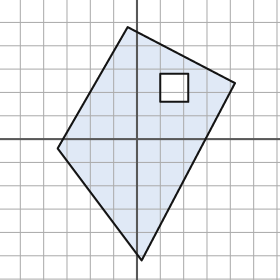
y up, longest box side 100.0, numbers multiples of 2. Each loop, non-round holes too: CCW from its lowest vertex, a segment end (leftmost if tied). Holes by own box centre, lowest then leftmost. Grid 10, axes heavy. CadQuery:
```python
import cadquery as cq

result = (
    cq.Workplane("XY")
    .moveTo(2.0, -52.0)
    .lineTo(42.0, 24.0)
    .lineTo(-4.0, 48.0)
    .lineTo(-34.0, -4.0)
    .close()
    .moveTo(10.0, 16.0)
    .lineTo(22.0, 16.0)
    .lineTo(22.0, 28.0)
    .lineTo(10.0, 28.0)
    .close()
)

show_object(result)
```